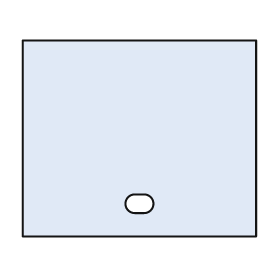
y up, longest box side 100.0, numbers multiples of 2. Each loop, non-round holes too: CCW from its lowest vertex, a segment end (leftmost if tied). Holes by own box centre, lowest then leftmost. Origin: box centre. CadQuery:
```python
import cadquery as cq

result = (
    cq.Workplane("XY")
    .moveTo(-50.0, -42.0)
    .lineTo(50.0, -42.0)
    .lineTo(50.0, 42.0)
    .lineTo(-50.0, 42.0)
    .close()
    .moveTo(-2.0, -32.0)
    .lineTo(2.0, -32.0)
    .threePointArc((6.0, -28.0), (2.0, -24.0))
    .lineTo(-2.0, -24.0)
    .threePointArc((-6.0, -28.0), (-2.0, -32.0))
    .close()
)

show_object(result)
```